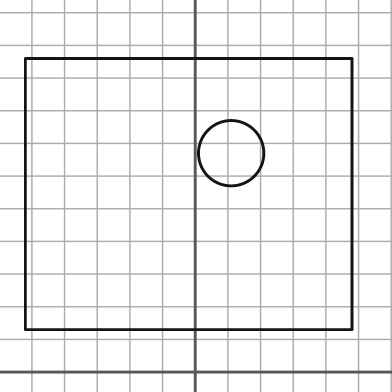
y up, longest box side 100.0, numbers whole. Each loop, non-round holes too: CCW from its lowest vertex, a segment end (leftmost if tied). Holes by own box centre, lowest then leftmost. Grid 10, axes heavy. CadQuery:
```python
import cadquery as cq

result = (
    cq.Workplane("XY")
    .moveTo(-52.0, 13.0)
    .lineTo(48.0, 13.0)
    .lineTo(48.0, 96.0)
    .lineTo(-52.0, 96.0)
    .close()
    .moveTo(11.0, 67.0)
    .circle(10.0)
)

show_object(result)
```